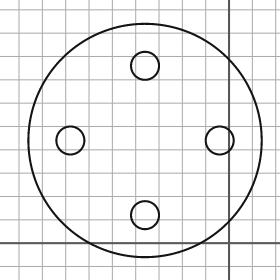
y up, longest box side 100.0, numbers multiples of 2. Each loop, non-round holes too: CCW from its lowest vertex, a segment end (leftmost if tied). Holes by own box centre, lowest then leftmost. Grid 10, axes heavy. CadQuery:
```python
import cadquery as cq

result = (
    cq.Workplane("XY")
    .moveTo(-36.0, 44.0)
    .circle(50.0)
    .moveTo(-36.0, 12.0)
    .circle(6.0)
    .moveTo(-68.0, 44.0)
    .circle(6.0)
    .moveTo(-4.0, 44.0)
    .circle(6.0)
    .moveTo(-36.0, 76.0)
    .circle(6.0)
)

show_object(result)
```